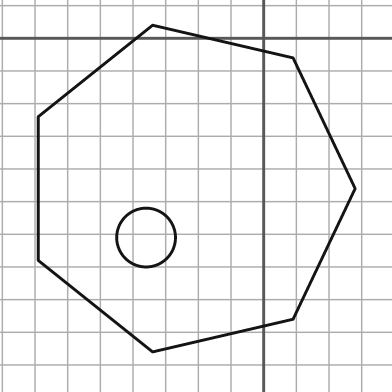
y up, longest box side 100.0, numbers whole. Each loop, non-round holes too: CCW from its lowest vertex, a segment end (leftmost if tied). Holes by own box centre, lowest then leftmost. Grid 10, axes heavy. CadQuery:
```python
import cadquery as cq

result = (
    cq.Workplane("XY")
    .moveTo(-34.0, -96.0)
    .lineTo(9.0, -86.0)
    .lineTo(28.0, -46.0)
    .lineTo(9.0, -6.0)
    .lineTo(-34.0, 4.0)
    .lineTo(-69.0, -24.0)
    .lineTo(-69.0, -68.0)
    .close()
    .moveTo(-36.0, -61.0)
    .circle(9.0)
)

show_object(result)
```